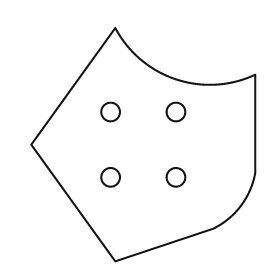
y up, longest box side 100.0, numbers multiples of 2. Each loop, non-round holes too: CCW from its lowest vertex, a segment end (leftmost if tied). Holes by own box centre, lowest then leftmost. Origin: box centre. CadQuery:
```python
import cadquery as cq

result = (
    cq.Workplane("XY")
    .moveTo(-12.0, -50.0)
    .lineTo(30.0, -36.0)
    .threePointArc((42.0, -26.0), (48.0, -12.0))
    .lineTo(48.0, 30.0)
    .threePointArc((14.0, 28.0), (-12.0, 50.0))
    .lineTo(-48.0, 0.0)
    .close()
    .moveTo(-14.0, -14.0)
    .circle(4.0)
    .moveTo(14.0, -14.0)
    .circle(4.0)
    .moveTo(-14.0, 14.0)
    .circle(4.0)
    .moveTo(14.0, 14.0)
    .circle(4.0)
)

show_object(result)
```